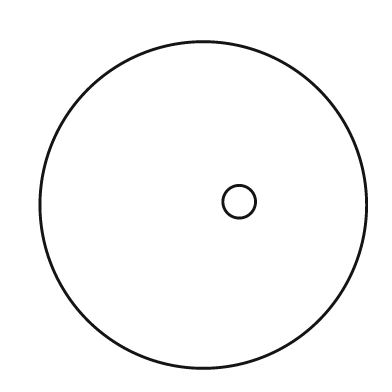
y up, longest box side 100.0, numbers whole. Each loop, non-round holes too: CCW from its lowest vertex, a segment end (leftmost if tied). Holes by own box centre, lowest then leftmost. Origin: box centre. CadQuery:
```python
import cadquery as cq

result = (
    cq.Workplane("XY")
    .moveTo(0.0, 0.0)
    .circle(50.0)
    .moveTo(11.0, 1.0)
    .circle(5.0)
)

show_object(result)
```